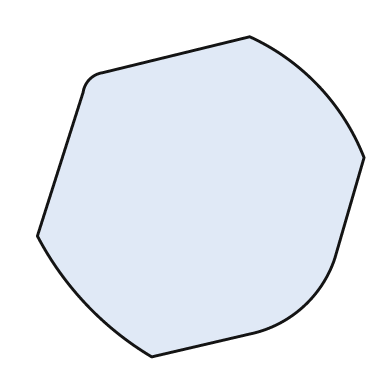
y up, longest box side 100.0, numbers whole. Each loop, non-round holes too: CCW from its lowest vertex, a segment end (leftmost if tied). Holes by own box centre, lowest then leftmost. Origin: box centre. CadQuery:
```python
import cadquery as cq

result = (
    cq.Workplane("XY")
    .moveTo(-15.0, -49.0)
    .lineTo(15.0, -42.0)
    .threePointArc((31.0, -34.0), (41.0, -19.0))
    .lineTo(50.0, 12.0)
    .threePointArc((36.0, 34.0), (15.0, 49.0))
    .lineTo(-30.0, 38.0)
    .threePointArc((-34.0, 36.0), (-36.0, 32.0))
    .lineTo(-50.0, -12.0)
    .threePointArc((-35.0, -33.0), (-15.0, -49.0))
    .close()
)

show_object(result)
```